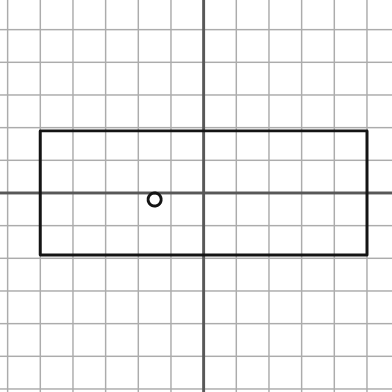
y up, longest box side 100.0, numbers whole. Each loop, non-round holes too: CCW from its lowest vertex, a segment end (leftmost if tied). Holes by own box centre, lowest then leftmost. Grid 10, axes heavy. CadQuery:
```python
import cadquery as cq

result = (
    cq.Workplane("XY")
    .moveTo(-50.0, -19.0)
    .lineTo(50.0, -19.0)
    .lineTo(50.0, 19.0)
    .lineTo(-50.0, 19.0)
    .close()
    .moveTo(-15.0, -2.0)
    .circle(2.0)
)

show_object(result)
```